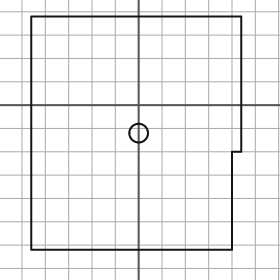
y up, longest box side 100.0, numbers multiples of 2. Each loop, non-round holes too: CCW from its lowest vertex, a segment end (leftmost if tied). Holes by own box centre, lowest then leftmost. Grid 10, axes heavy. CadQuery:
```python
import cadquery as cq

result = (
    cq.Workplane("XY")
    .moveTo(-46.0, -62.0)
    .lineTo(40.0, -62.0)
    .lineTo(40.0, -20.0)
    .lineTo(44.0, -20.0)
    .lineTo(44.0, 38.0)
    .lineTo(-46.0, 38.0)
    .close()
    .moveTo(0.0, -12.0)
    .circle(4.0)
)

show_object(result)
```